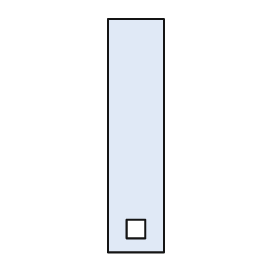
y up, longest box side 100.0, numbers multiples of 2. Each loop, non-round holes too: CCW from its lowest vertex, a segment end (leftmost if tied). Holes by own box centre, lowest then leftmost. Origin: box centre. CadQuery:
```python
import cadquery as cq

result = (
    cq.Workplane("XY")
    .moveTo(-12.0, -50.0)
    .lineTo(12.0, -50.0)
    .lineTo(12.0, 50.0)
    .lineTo(-12.0, 50.0)
    .close()
    .moveTo(-4.0, -44.0)
    .lineTo(4.0, -44.0)
    .lineTo(4.0, -36.0)
    .lineTo(-4.0, -36.0)
    .close()
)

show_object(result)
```